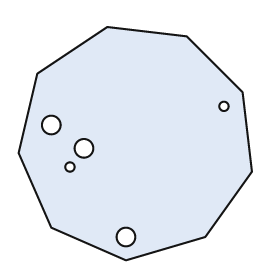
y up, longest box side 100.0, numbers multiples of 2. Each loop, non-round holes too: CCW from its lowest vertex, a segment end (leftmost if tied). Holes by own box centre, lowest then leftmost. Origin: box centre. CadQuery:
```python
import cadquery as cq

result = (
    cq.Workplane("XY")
    .moveTo(-4.0, -50.0)
    .lineTo(30.0, -40.0)
    .lineTo(50.0, -12.0)
    .lineTo(46.0, 22.0)
    .lineTo(22.0, 46.0)
    .lineTo(-12.0, 50.0)
    .lineTo(-42.0, 30.0)
    .lineTo(-50.0, -4.0)
    .lineTo(-36.0, -36.0)
    .close()
    .moveTo(-4.0, -40.0)
    .circle(4.0)
    .moveTo(-28.0, -10.0)
    .circle(2.0)
    .moveTo(-22.0, -2.0)
    .circle(4.0)
    .moveTo(-36.0, 8.0)
    .circle(4.0)
    .moveTo(38.0, 16.0)
    .circle(2.0)
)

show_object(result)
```